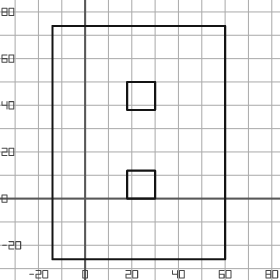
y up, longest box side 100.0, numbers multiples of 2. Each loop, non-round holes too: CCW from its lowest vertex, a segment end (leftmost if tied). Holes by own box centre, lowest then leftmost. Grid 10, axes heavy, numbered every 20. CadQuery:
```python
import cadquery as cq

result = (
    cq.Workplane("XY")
    .moveTo(-14.0, -26.0)
    .lineTo(60.0, -26.0)
    .lineTo(60.0, 74.0)
    .lineTo(-14.0, 74.0)
    .close()
    .moveTo(18.0, 0.0)
    .lineTo(30.0, 0.0)
    .lineTo(30.0, 12.0)
    .lineTo(18.0, 12.0)
    .close()
    .moveTo(18.0, 38.0)
    .lineTo(30.0, 38.0)
    .lineTo(30.0, 50.0)
    .lineTo(18.0, 50.0)
    .close()
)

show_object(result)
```